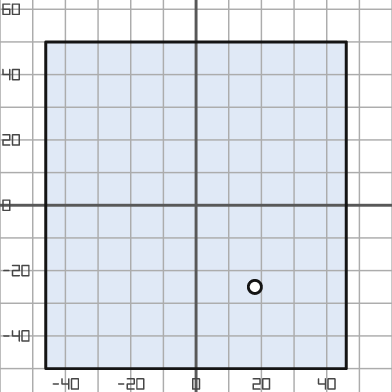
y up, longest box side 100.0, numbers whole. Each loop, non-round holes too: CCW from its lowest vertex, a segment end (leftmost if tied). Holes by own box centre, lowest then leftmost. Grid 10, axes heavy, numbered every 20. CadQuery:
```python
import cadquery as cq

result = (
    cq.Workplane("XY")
    .moveTo(-46.0, -50.0)
    .lineTo(46.0, -50.0)
    .lineTo(46.0, 50.0)
    .lineTo(-46.0, 50.0)
    .close()
    .moveTo(18.0, -25.0)
    .circle(2.0)
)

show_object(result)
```